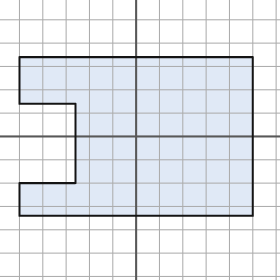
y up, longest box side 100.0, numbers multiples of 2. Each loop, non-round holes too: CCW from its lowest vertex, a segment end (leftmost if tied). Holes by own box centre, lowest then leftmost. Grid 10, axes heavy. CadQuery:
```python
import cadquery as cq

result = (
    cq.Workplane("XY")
    .moveTo(-50.0, -34.0)
    .lineTo(50.0, -34.0)
    .lineTo(50.0, 34.0)
    .lineTo(-50.0, 34.0)
    .lineTo(-50.0, 14.0)
    .lineTo(-26.0, 14.0)
    .lineTo(-26.0, -20.0)
    .lineTo(-50.0, -20.0)
    .close()
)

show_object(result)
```